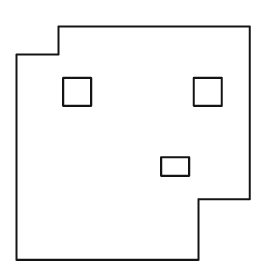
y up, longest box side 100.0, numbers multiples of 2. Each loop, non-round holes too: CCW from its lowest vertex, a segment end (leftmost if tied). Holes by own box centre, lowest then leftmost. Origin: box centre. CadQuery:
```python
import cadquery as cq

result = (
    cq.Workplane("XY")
    .moveTo(-50.0, -50.0)
    .lineTo(28.0, -50.0)
    .lineTo(28.0, -24.0)
    .lineTo(50.0, -24.0)
    .lineTo(50.0, 50.0)
    .lineTo(-32.0, 50.0)
    .lineTo(-32.0, 38.0)
    .lineTo(-50.0, 38.0)
    .close()
    .moveTo(12.0, -14.0)
    .lineTo(24.0, -14.0)
    .lineTo(24.0, -6.0)
    .lineTo(12.0, -6.0)
    .close()
    .moveTo(-30.0, 16.0)
    .lineTo(-18.0, 16.0)
    .lineTo(-18.0, 28.0)
    .lineTo(-30.0, 28.0)
    .close()
    .moveTo(26.0, 16.0)
    .lineTo(38.0, 16.0)
    .lineTo(38.0, 28.0)
    .lineTo(26.0, 28.0)
    .close()
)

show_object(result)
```